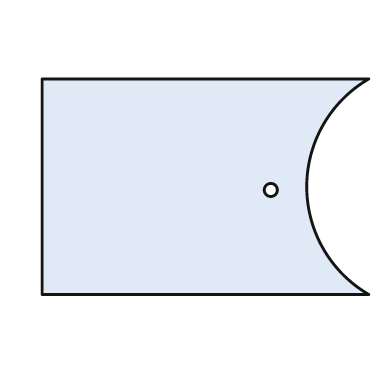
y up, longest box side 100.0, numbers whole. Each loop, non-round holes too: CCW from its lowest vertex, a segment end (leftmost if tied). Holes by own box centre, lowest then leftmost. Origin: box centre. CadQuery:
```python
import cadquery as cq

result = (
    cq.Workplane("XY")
    .moveTo(-50.0, -33.0)
    .lineTo(50.0, -33.0)
    .threePointArc((31.0, 0.0), (50.0, 33.0))
    .lineTo(-50.0, 33.0)
    .close()
    .moveTo(20.0, -1.0)
    .circle(2.0)
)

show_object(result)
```